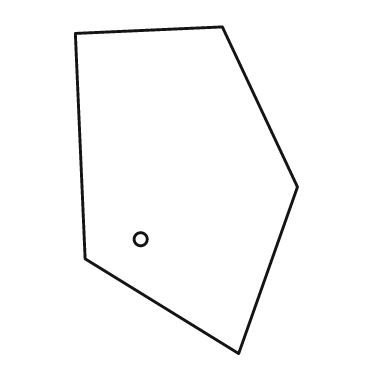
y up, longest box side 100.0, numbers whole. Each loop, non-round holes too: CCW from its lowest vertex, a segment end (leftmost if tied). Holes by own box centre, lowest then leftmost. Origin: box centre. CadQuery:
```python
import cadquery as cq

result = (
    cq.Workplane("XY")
    .moveTo(16.0, -50.0)
    .lineTo(34.0, 1.0)
    .lineTo(11.0, 50.0)
    .lineTo(-34.0, 48.0)
    .lineTo(-31.0, -21.0)
    .close()
    .moveTo(-14.0, -15.0)
    .circle(2.0)
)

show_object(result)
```